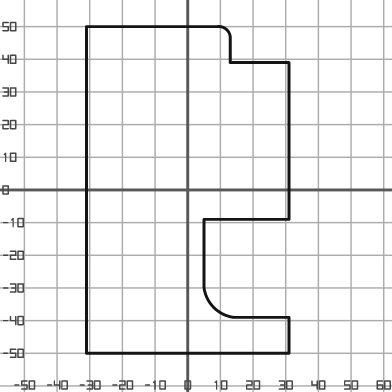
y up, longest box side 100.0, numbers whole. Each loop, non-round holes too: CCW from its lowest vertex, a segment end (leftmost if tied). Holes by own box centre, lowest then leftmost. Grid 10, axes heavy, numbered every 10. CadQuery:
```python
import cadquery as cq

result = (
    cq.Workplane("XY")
    .moveTo(-31.0, -50.0)
    .lineTo(31.0, -50.0)
    .lineTo(31.0, -39.0)
    .lineTo(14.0, -39.0)
    .threePointArc((8.0, -36.0), (5.0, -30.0))
    .lineTo(5.0, -9.0)
    .lineTo(31.0, -9.0)
    .lineTo(31.0, 39.0)
    .lineTo(13.0, 39.0)
    .lineTo(13.0, 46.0)
    .threePointArc((12.0, 49.0), (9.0, 50.0))
    .lineTo(-31.0, 50.0)
    .close()
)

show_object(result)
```